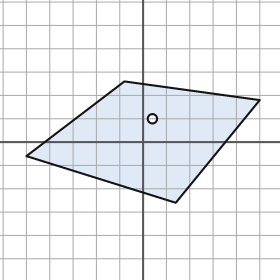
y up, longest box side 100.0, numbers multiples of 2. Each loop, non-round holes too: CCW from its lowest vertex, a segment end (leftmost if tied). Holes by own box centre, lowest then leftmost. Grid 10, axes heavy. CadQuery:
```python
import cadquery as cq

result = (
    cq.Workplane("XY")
    .moveTo(14.0, -26.0)
    .lineTo(50.0, 18.0)
    .lineTo(-8.0, 26.0)
    .lineTo(-50.0, -6.0)
    .close()
    .moveTo(4.0, 10.0)
    .circle(2.0)
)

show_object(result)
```